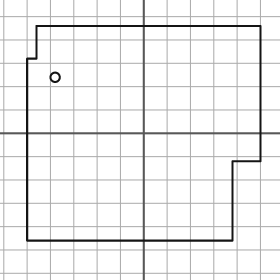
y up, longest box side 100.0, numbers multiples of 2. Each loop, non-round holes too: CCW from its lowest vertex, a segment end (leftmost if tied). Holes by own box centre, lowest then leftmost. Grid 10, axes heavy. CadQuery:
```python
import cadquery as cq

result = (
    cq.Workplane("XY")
    .moveTo(-50.0, -46.0)
    .lineTo(38.0, -46.0)
    .lineTo(38.0, -12.0)
    .lineTo(50.0, -12.0)
    .lineTo(50.0, 46.0)
    .lineTo(-46.0, 46.0)
    .lineTo(-46.0, 32.0)
    .lineTo(-50.0, 32.0)
    .close()
    .moveTo(-38.0, 24.0)
    .circle(2.0)
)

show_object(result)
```